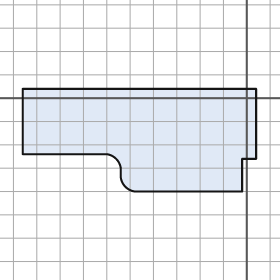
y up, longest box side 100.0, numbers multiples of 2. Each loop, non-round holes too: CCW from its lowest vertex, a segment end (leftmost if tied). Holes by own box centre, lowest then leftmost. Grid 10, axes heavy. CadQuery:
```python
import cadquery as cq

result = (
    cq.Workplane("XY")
    .moveTo(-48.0, -40.0)
    .lineTo(-2.0, -40.0)
    .lineTo(-2.0, -26.0)
    .lineTo(4.0, -26.0)
    .lineTo(4.0, 4.0)
    .lineTo(-96.0, 4.0)
    .lineTo(-96.0, -24.0)
    .lineTo(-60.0, -24.0)
    .threePointArc((-56.0, -26.0), (-54.0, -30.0))
    .lineTo(-54.0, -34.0)
    .threePointArc((-52.0, -38.0), (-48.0, -40.0))
    .close()
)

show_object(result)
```